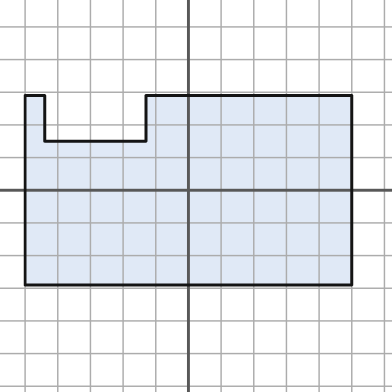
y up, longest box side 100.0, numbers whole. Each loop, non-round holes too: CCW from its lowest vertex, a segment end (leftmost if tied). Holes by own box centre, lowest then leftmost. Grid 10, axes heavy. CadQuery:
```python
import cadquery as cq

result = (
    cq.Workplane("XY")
    .moveTo(-50.0, -29.0)
    .lineTo(50.0, -29.0)
    .lineTo(50.0, 29.0)
    .lineTo(-13.0, 29.0)
    .lineTo(-13.0, 15.0)
    .lineTo(-44.0, 15.0)
    .lineTo(-44.0, 29.0)
    .lineTo(-50.0, 29.0)
    .close()
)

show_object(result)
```